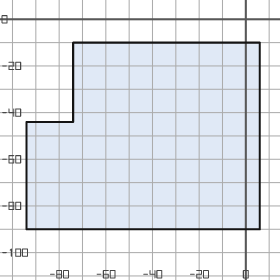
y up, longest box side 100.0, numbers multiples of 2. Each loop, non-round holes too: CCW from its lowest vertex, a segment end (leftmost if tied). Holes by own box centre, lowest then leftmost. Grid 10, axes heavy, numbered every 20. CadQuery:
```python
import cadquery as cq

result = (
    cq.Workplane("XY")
    .moveTo(-94.0, -90.0)
    .lineTo(6.0, -90.0)
    .lineTo(6.0, -10.0)
    .lineTo(-74.0, -10.0)
    .lineTo(-74.0, -44.0)
    .lineTo(-94.0, -44.0)
    .close()
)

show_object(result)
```